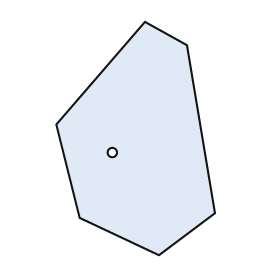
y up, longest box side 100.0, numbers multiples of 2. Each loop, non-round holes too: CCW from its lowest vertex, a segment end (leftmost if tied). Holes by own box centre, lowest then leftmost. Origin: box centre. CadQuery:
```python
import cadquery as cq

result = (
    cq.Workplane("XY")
    .moveTo(10.0, -50.0)
    .lineTo(34.0, -32.0)
    .lineTo(22.0, 40.0)
    .lineTo(4.0, 50.0)
    .lineTo(-34.0, 6.0)
    .lineTo(-24.0, -34.0)
    .close()
    .moveTo(-10.0, -6.0)
    .circle(2.0)
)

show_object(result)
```